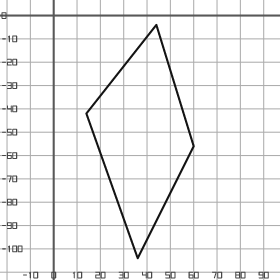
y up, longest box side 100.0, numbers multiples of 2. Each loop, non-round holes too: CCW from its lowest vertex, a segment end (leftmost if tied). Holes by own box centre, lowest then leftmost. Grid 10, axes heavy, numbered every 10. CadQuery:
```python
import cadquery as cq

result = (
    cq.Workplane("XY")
    .moveTo(36.0, -104.0)
    .lineTo(60.0, -56.0)
    .lineTo(44.0, -4.0)
    .lineTo(14.0, -42.0)
    .close()
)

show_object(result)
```